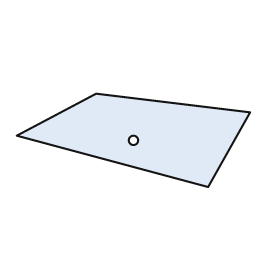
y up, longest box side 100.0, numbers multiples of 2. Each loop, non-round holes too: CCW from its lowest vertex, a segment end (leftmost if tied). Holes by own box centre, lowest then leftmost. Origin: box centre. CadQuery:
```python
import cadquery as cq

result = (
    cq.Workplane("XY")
    .moveTo(32.0, -20.0)
    .lineTo(50.0, 12.0)
    .lineTo(-16.0, 20.0)
    .lineTo(-50.0, 2.0)
    .close()
    .moveTo(0.0, 0.0)
    .circle(2.0)
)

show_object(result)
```